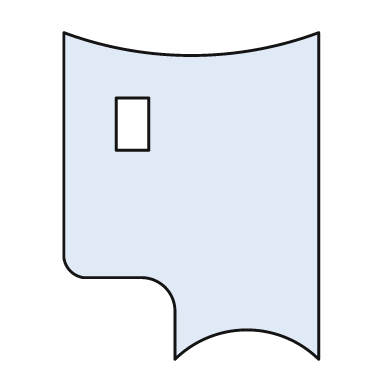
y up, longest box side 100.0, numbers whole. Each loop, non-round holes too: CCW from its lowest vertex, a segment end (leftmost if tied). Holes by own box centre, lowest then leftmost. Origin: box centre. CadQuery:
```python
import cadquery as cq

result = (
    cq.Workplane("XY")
    .moveTo(-5.0, -50.0)
    .threePointArc((17.0, -41.0), (39.0, -50.0))
    .lineTo(39.0, 50.0)
    .threePointArc((0.0, 43.0), (-39.0, 50.0))
    .lineTo(-39.0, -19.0)
    .threePointArc((-37.0, -23.0), (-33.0, -25.0))
    .lineTo(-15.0, -25.0)
    .threePointArc((-8.0, -28.0), (-5.0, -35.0))
    .close()
    .moveTo(-23.0, 14.0)
    .lineTo(-13.0, 14.0)
    .lineTo(-13.0, 30.0)
    .lineTo(-23.0, 30.0)
    .close()
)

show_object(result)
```